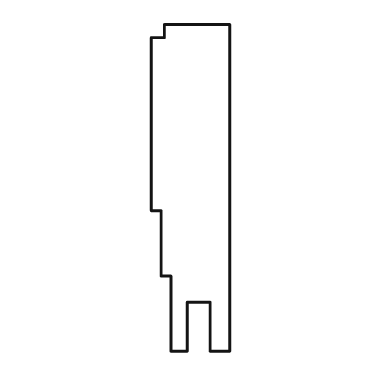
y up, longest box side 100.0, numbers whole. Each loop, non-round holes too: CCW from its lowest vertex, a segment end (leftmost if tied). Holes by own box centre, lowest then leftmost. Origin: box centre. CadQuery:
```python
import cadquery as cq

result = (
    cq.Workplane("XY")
    .moveTo(-6.0, -50.0)
    .lineTo(-1.0, -50.0)
    .lineTo(-1.0, -35.0)
    .lineTo(6.0, -35.0)
    .lineTo(6.0, -50.0)
    .lineTo(12.0, -50.0)
    .lineTo(12.0, 50.0)
    .lineTo(-8.0, 50.0)
    .lineTo(-8.0, 46.0)
    .lineTo(-12.0, 46.0)
    .lineTo(-12.0, -7.0)
    .lineTo(-9.0, -7.0)
    .lineTo(-9.0, -27.0)
    .lineTo(-6.0, -27.0)
    .close()
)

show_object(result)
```